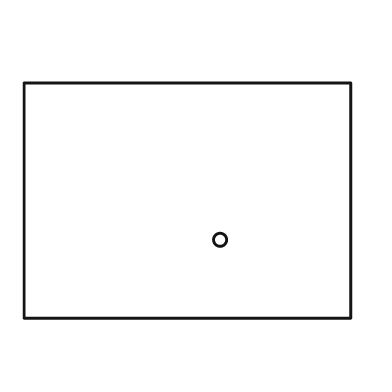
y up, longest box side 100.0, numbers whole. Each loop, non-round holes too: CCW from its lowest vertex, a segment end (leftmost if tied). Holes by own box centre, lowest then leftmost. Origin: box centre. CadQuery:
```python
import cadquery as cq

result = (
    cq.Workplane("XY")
    .moveTo(-50.0, -36.0)
    .lineTo(50.0, -36.0)
    .lineTo(50.0, 36.0)
    .lineTo(-50.0, 36.0)
    .close()
    .moveTo(10.0, -12.0)
    .circle(2.0)
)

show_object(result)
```